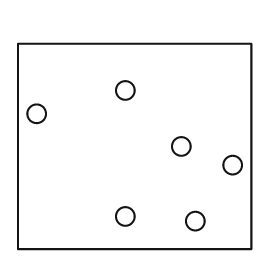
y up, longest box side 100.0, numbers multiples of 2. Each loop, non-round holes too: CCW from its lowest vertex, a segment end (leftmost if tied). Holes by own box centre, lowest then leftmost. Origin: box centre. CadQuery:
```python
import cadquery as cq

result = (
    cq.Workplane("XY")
    .moveTo(-50.0, -44.0)
    .lineTo(50.0, -44.0)
    .lineTo(50.0, 44.0)
    .lineTo(-50.0, 44.0)
    .close()
    .moveTo(26.0, -32.0)
    .circle(4.0)
    .moveTo(-4.0, -30.0)
    .circle(4.0)
    .moveTo(42.0, -8.0)
    .circle(4.0)
    .moveTo(20.0, 0.0)
    .circle(4.0)
    .moveTo(-42.0, 14.0)
    .circle(4.0)
    .moveTo(-4.0, 24.0)
    .circle(4.0)
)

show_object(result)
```